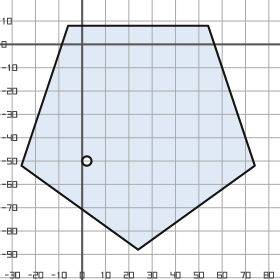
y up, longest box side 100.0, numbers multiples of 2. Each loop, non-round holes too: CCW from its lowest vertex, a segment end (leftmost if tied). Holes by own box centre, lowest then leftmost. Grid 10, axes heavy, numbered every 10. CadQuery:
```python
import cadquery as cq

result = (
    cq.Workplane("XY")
    .moveTo(24.0, -88.0)
    .lineTo(74.0, -52.0)
    .lineTo(54.0, 8.0)
    .lineTo(-6.0, 8.0)
    .lineTo(-26.0, -52.0)
    .close()
    .moveTo(2.0, -50.0)
    .circle(2.0)
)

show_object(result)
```